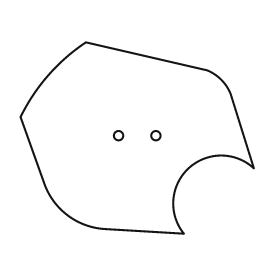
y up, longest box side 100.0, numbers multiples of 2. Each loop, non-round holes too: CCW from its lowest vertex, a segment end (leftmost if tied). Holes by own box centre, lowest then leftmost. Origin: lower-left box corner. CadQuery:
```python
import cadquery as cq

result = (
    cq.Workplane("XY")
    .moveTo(70.0, 0.0)
    .threePointArc((72.0, 28.0), (100.0, 28.0))
    .lineTo(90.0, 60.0)
    .threePointArc((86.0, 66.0), (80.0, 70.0))
    .lineTo(28.0, 82.0)
    .threePointArc((12.0, 68.0), (0.0, 50.0))
    .lineTo(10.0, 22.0)
    .threePointArc((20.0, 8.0), (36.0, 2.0))
    .close()
    .moveTo(42.0, 42.0)
    .circle(2.0)
    .moveTo(58.0, 42.0)
    .circle(2.0)
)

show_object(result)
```